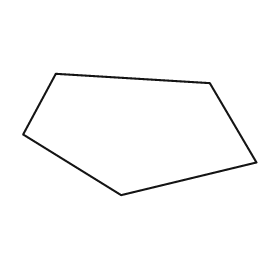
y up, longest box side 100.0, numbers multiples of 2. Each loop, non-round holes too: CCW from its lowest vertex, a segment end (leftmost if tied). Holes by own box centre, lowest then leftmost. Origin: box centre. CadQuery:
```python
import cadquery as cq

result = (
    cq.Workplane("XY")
    .moveTo(-8.0, -26.0)
    .lineTo(50.0, -12.0)
    .lineTo(30.0, 22.0)
    .lineTo(-36.0, 26.0)
    .lineTo(-50.0, 0.0)
    .close()
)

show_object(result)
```